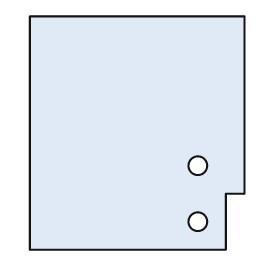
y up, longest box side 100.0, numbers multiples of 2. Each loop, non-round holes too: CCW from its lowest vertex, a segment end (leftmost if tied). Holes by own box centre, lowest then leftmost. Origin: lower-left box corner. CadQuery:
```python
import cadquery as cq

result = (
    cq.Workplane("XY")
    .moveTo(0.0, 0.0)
    .lineTo(84.0, 0.0)
    .lineTo(84.0, 24.0)
    .lineTo(92.0, 24.0)
    .lineTo(92.0, 100.0)
    .lineTo(0.0, 100.0)
    .close()
    .moveTo(72.0, 12.0)
    .circle(4.0)
    .moveTo(72.0, 36.0)
    .circle(4.0)
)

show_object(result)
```